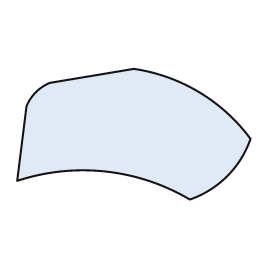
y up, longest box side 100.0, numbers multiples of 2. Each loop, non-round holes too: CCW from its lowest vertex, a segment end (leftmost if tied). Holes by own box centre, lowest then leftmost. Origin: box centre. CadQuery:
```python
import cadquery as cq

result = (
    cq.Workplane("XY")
    .moveTo(24.0, -28.0)
    .threePointArc((40.0, -18.0), (50.0, -2.0))
    .threePointArc((28.0, 18.0), (0.0, 28.0))
    .lineTo(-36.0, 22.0)
    .threePointArc((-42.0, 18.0), (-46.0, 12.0))
    .lineTo(-50.0, -20.0)
    .threePointArc((-12.0, -16.0), (24.0, -28.0))
    .close()
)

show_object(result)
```